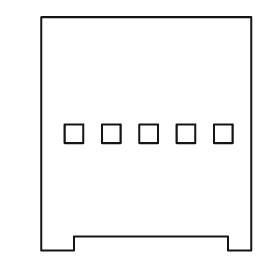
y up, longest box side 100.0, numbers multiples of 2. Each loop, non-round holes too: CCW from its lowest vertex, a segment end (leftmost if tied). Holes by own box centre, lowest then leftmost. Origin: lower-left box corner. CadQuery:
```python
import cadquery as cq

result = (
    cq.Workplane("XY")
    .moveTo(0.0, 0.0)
    .lineTo(14.0, 0.0)
    .lineTo(14.0, 6.0)
    .lineTo(80.0, 6.0)
    .lineTo(80.0, 0.0)
    .lineTo(90.0, 0.0)
    .lineTo(90.0, 100.0)
    .lineTo(0.0, 100.0)
    .close()
    .moveTo(10.0, 46.0)
    .lineTo(18.0, 46.0)
    .lineTo(18.0, 54.0)
    .lineTo(10.0, 54.0)
    .close()
    .moveTo(26.0, 46.0)
    .lineTo(34.0, 46.0)
    .lineTo(34.0, 54.0)
    .lineTo(26.0, 54.0)
    .close()
    .moveTo(42.0, 46.0)
    .lineTo(50.0, 46.0)
    .lineTo(50.0, 54.0)
    .lineTo(42.0, 54.0)
    .close()
    .moveTo(58.0, 46.0)
    .lineTo(66.0, 46.0)
    .lineTo(66.0, 54.0)
    .lineTo(58.0, 54.0)
    .close()
    .moveTo(74.0, 46.0)
    .lineTo(82.0, 46.0)
    .lineTo(82.0, 54.0)
    .lineTo(74.0, 54.0)
    .close()
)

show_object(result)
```